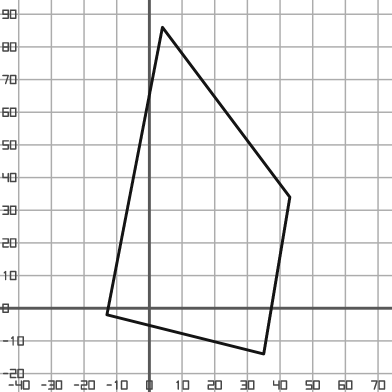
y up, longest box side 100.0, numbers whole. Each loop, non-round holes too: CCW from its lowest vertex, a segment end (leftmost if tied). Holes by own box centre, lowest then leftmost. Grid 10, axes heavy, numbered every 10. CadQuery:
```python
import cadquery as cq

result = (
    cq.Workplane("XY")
    .moveTo(35.0, -14.0)
    .lineTo(43.0, 34.0)
    .lineTo(4.0, 86.0)
    .lineTo(-13.0, -2.0)
    .close()
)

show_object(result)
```